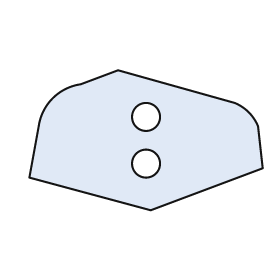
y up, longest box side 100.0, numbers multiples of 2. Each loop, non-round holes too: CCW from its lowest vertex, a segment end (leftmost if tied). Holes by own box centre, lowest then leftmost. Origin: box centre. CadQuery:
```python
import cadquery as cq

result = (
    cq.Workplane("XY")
    .moveTo(2.0, -30.0)
    .lineTo(50.0, -12.0)
    .lineTo(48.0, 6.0)
    .threePointArc((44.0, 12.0), (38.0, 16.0))
    .lineTo(-12.0, 30.0)
    .lineTo(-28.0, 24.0)
    .threePointArc((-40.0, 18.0), (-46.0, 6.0))
    .lineTo(-50.0, -16.0)
    .close()
    .moveTo(0.0, -10.0)
    .circle(6.0)
    .moveTo(0.0, 10.0)
    .circle(6.0)
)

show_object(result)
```